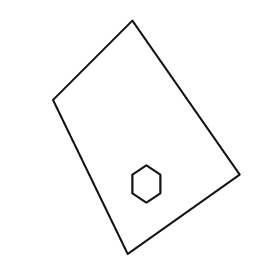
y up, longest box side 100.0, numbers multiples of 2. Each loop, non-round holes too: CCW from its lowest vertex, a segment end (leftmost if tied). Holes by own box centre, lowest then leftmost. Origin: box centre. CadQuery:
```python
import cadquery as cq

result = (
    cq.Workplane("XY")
    .moveTo(-8.0, -50.0)
    .lineTo(40.0, -16.0)
    .lineTo(-6.0, 50.0)
    .lineTo(-40.0, 16.0)
    .close()
    .moveTo(0.0, -28.0)
    .lineTo(6.0, -24.0)
    .lineTo(6.0, -16.0)
    .lineTo(0.0, -12.0)
    .lineTo(-6.0, -16.0)
    .lineTo(-6.0, -24.0)
    .close()
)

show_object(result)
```